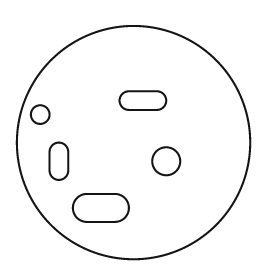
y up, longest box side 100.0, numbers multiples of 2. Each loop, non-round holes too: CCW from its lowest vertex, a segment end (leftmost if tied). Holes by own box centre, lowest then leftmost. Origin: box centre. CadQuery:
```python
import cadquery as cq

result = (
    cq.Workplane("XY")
    .moveTo(0.0, 0.0)
    .circle(50.0)
    .moveTo(-20.0, -34.0)
    .lineTo(-8.0, -34.0)
    .threePointArc((-2.0, -28.0), (-8.0, -22.0))
    .lineTo(-20.0, -22.0)
    .threePointArc((-26.0, -28.0), (-20.0, -34.0))
    .close()
    .moveTo(-36.0, -12.0)
    .threePointArc((-32.0, -16.0), (-28.0, -12.0))
    .lineTo(-28.0, -4.0)
    .threePointArc((-32.0, 0.0), (-36.0, -4.0))
    .close()
    .moveTo(14.0, -8.0)
    .circle(6.0)
    .moveTo(-40.0, 12.0)
    .circle(4.0)
    .moveTo(-2.0, 14.0)
    .lineTo(10.0, 14.0)
    .threePointArc((14.0, 18.0), (10.0, 22.0))
    .lineTo(-2.0, 22.0)
    .threePointArc((-6.0, 18.0), (-2.0, 14.0))
    .close()
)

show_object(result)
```